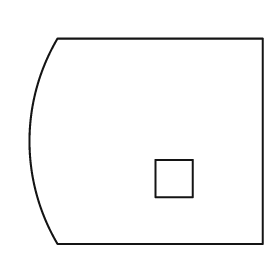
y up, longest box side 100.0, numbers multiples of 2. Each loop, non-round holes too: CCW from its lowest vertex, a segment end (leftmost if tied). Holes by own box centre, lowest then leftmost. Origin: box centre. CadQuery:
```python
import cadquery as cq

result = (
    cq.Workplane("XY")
    .moveTo(-38.0, -44.0)
    .lineTo(50.0, -44.0)
    .lineTo(50.0, 44.0)
    .lineTo(-38.0, 44.0)
    .threePointArc((-50.0, 0.0), (-38.0, -44.0))
    .close()
    .moveTo(4.0, -24.0)
    .lineTo(20.0, -24.0)
    .lineTo(20.0, -8.0)
    .lineTo(4.0, -8.0)
    .close()
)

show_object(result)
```